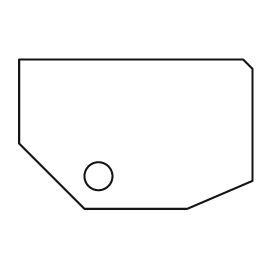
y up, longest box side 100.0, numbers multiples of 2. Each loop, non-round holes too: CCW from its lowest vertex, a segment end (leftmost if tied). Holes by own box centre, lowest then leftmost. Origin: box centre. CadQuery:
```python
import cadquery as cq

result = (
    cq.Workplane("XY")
    .moveTo(-22.0, -32.0)
    .lineTo(22.0, -32.0)
    .lineTo(50.0, -20.0)
    .lineTo(50.0, 28.0)
    .lineTo(46.0, 32.0)
    .lineTo(-50.0, 32.0)
    .lineTo(-50.0, -4.0)
    .close()
    .moveTo(-16.0, -18.0)
    .circle(6.0)
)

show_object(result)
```